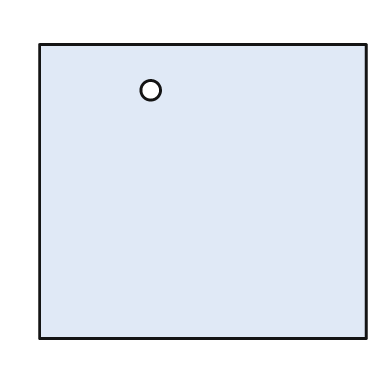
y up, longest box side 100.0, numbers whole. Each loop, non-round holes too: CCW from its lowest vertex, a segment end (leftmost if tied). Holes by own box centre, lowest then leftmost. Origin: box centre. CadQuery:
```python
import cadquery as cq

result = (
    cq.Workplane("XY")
    .moveTo(-50.0, -45.0)
    .lineTo(50.0, -45.0)
    .lineTo(50.0, 45.0)
    .lineTo(-50.0, 45.0)
    .close()
    .moveTo(-16.0, 31.0)
    .circle(3.0)
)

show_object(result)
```